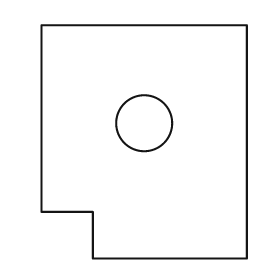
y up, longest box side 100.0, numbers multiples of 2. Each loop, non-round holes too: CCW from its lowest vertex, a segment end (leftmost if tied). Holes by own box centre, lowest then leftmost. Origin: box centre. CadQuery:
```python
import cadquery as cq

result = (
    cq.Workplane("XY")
    .moveTo(-22.0, -50.0)
    .lineTo(44.0, -50.0)
    .lineTo(44.0, 50.0)
    .lineTo(-44.0, 50.0)
    .lineTo(-44.0, -30.0)
    .lineTo(-22.0, -30.0)
    .close()
    .moveTo(0.0, 8.0)
    .circle(12.0)
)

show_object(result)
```